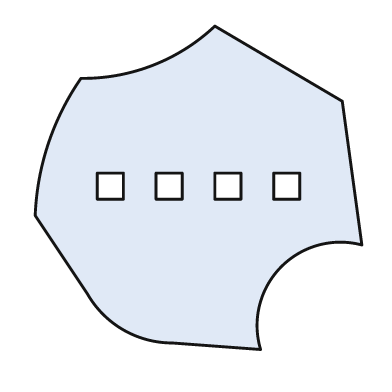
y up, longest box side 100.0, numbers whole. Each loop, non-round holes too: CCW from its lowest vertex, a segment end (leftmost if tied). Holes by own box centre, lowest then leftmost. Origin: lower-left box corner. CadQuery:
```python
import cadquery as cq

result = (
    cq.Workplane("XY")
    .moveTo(69.0, 0.0)
    .threePointArc((75.0, 25.0), (100.0, 32.0))
    .lineTo(94.0, 76.0)
    .lineTo(55.0, 99.0)
    .threePointArc((36.0, 87.0), (14.0, 83.0))
    .threePointArc((4.0, 63.0), (0.0, 41.0))
    .lineTo(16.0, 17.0)
    .threePointArc((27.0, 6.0), (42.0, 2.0))
    .close()
    .moveTo(19.0, 46.0)
    .lineTo(27.0, 46.0)
    .lineTo(27.0, 54.0)
    .lineTo(19.0, 54.0)
    .close()
    .moveTo(37.0, 46.0)
    .lineTo(45.0, 46.0)
    .lineTo(45.0, 54.0)
    .lineTo(37.0, 54.0)
    .close()
    .moveTo(55.0, 46.0)
    .lineTo(63.0, 46.0)
    .lineTo(63.0, 54.0)
    .lineTo(55.0, 54.0)
    .close()
    .moveTo(73.0, 46.0)
    .lineTo(81.0, 46.0)
    .lineTo(81.0, 54.0)
    .lineTo(73.0, 54.0)
    .close()
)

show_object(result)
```